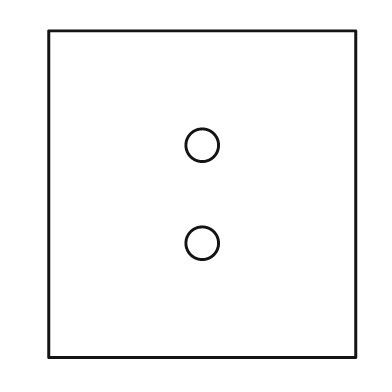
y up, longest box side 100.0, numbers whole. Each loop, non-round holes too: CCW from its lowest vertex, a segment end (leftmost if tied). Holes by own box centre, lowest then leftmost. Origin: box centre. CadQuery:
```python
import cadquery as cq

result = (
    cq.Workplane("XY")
    .moveTo(-47.0, -50.0)
    .lineTo(47.0, -50.0)
    .lineTo(47.0, 50.0)
    .lineTo(-47.0, 50.0)
    .close()
    .moveTo(0.0, -15.0)
    .circle(5.0)
    .moveTo(0.0, 15.0)
    .circle(5.0)
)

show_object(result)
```